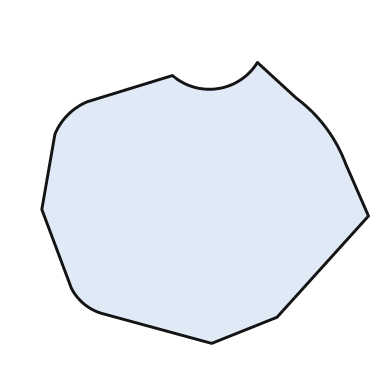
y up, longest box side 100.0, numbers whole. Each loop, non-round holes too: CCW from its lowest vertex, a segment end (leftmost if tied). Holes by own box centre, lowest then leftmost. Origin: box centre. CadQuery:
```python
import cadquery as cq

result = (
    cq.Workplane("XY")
    .moveTo(2.0, -43.0)
    .lineTo(22.0, -35.0)
    .lineTo(50.0, -4.0)
    .lineTo(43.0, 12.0)
    .threePointArc((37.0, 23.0), (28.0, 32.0))
    .lineTo(16.0, 43.0)
    .threePointArc((4.0, 35.0), (-10.0, 39.0))
    .lineTo(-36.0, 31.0)
    .threePointArc((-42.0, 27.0), (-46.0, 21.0))
    .lineTo(-50.0, -2.0)
    .lineTo(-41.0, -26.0)
    .threePointArc((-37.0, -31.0), (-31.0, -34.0))
    .close()
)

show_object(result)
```